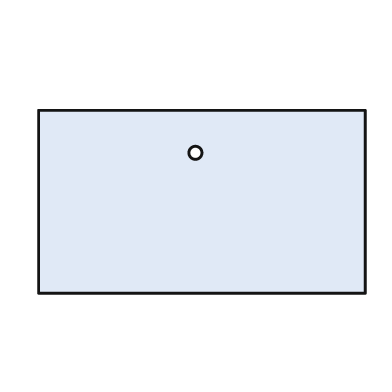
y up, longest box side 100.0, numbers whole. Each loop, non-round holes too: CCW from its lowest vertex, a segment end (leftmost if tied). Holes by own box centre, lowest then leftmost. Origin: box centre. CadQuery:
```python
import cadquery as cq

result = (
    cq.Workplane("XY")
    .moveTo(-50.0, -28.0)
    .lineTo(50.0, -28.0)
    .lineTo(50.0, 28.0)
    .lineTo(-50.0, 28.0)
    .close()
    .moveTo(-2.0, 15.0)
    .circle(2.0)
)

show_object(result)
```